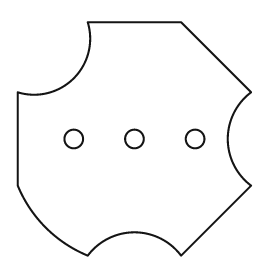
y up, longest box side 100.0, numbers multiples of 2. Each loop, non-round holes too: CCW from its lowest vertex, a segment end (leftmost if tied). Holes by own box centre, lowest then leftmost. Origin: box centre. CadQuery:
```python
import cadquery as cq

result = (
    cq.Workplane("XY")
    .moveTo(-20.0, -50.0)
    .threePointArc((0.0, -40.0), (20.0, -50.0))
    .lineTo(50.0, -20.0)
    .threePointArc((40.0, 0.0), (50.0, 20.0))
    .lineTo(20.0, 50.0)
    .lineTo(-20.0, 50.0)
    .threePointArc((-26.0, 26.0), (-50.0, 20.0))
    .lineTo(-50.0, -20.0)
    .threePointArc((-38.0, -38.0), (-20.0, -50.0))
    .close()
    .moveTo(-26.0, 0.0)
    .circle(4.0)
    .moveTo(0.0, 0.0)
    .circle(4.0)
    .moveTo(26.0, 0.0)
    .circle(4.0)
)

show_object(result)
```